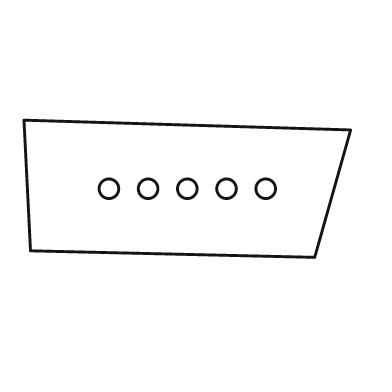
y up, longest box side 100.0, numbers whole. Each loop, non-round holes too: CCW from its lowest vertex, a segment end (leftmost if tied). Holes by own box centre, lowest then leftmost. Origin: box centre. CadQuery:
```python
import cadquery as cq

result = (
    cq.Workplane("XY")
    .moveTo(39.0, -21.0)
    .lineTo(50.0, 18.0)
    .lineTo(-50.0, 21.0)
    .lineTo(-48.0, -19.0)
    .close()
    .moveTo(-24.0, 0.0)
    .circle(3.0)
    .moveTo(-12.0, 0.0)
    .circle(3.0)
    .moveTo(0.0, 0.0)
    .circle(3.0)
    .moveTo(12.0, 0.0)
    .circle(3.0)
    .moveTo(24.0, 0.0)
    .circle(3.0)
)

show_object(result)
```